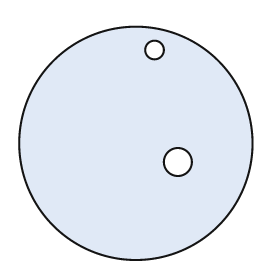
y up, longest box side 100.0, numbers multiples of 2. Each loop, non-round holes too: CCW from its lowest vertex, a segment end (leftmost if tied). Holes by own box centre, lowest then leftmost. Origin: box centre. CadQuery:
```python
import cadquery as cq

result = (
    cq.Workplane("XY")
    .moveTo(0.0, 0.0)
    .circle(50.0)
    .moveTo(18.0, -8.0)
    .circle(6.0)
    .moveTo(8.0, 40.0)
    .circle(4.0)
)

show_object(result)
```